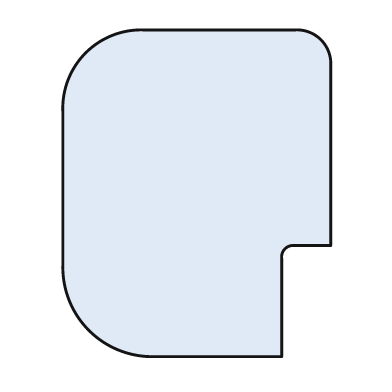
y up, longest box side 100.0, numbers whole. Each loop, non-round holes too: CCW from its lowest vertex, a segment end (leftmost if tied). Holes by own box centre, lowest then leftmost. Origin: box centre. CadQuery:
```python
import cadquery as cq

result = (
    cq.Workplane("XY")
    .moveTo(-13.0, -50.0)
    .lineTo(26.0, -50.0)
    .lineTo(26.0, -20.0)
    .threePointArc((27.0, -17.0), (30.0, -16.0))
    .lineTo(41.0, -16.0)
    .lineTo(41.0, 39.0)
    .threePointArc((38.0, 47.0), (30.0, 50.0))
    .lineTo(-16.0, 50.0)
    .threePointArc((-34.0, 43.0), (-41.0, 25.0))
    .lineTo(-41.0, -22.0)
    .threePointArc((-33.0, -42.0), (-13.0, -50.0))
    .close()
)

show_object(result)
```